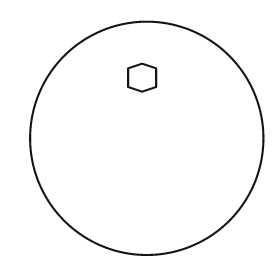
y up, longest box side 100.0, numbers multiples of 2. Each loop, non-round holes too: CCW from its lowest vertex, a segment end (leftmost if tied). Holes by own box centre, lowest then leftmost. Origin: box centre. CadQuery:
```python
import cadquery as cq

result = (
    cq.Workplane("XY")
    .moveTo(0.0, 0.0)
    .circle(50.0)
    .moveTo(-2.0, 20.0)
    .lineTo(4.0, 22.0)
    .lineTo(4.0, 30.0)
    .lineTo(-2.0, 32.0)
    .lineTo(-8.0, 30.0)
    .lineTo(-8.0, 22.0)
    .close()
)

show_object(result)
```